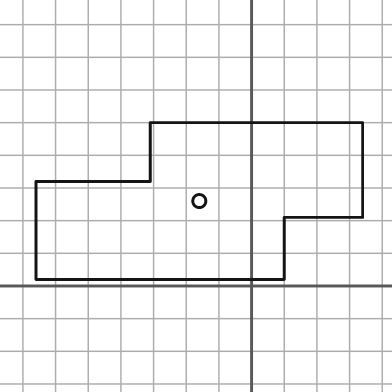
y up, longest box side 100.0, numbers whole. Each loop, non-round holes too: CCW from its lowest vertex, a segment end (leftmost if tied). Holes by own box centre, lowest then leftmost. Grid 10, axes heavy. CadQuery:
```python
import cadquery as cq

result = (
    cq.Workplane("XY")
    .moveTo(-66.0, 2.0)
    .lineTo(10.0, 2.0)
    .lineTo(10.0, 21.0)
    .lineTo(34.0, 21.0)
    .lineTo(34.0, 50.0)
    .lineTo(-31.0, 50.0)
    .lineTo(-31.0, 32.0)
    .lineTo(-66.0, 32.0)
    .close()
    .moveTo(-16.0, 26.0)
    .circle(2.0)
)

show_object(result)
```